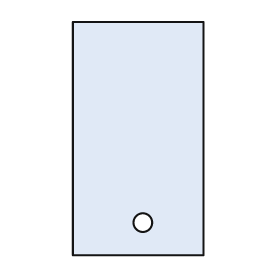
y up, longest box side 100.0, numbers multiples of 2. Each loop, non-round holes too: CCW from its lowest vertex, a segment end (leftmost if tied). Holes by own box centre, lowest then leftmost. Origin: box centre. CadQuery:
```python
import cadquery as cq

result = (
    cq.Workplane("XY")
    .moveTo(-28.0, -50.0)
    .lineTo(28.0, -50.0)
    .lineTo(28.0, 50.0)
    .lineTo(-28.0, 50.0)
    .close()
    .moveTo(2.0, -36.0)
    .circle(4.0)
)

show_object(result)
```